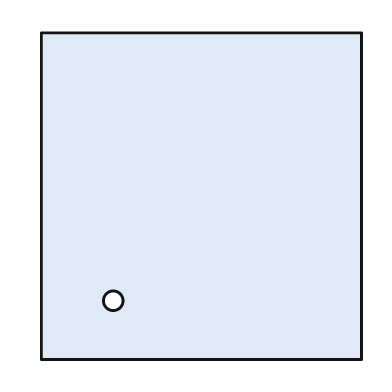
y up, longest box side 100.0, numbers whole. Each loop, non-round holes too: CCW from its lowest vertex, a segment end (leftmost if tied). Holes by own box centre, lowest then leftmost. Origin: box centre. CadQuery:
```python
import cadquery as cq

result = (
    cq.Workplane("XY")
    .moveTo(-49.0, -50.0)
    .lineTo(49.0, -50.0)
    .lineTo(49.0, 50.0)
    .lineTo(-49.0, 50.0)
    .close()
    .moveTo(-27.0, -32.0)
    .circle(3.0)
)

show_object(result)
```